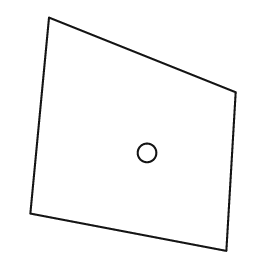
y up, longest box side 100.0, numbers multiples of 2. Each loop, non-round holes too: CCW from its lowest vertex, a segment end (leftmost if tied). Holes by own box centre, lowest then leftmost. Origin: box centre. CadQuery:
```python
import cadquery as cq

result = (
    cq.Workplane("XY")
    .moveTo(40.0, -50.0)
    .lineTo(44.0, 18.0)
    .lineTo(-36.0, 50.0)
    .lineTo(-44.0, -34.0)
    .close()
    .moveTo(6.0, -8.0)
    .circle(4.0)
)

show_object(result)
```